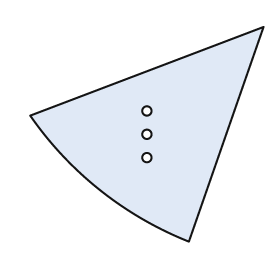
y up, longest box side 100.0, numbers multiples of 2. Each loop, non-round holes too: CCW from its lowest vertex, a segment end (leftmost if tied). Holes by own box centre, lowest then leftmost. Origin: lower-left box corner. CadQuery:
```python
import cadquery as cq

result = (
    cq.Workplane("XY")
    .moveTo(68.0, 0.0)
    .lineTo(100.0, 92.0)
    .lineTo(0.0, 54.0)
    .threePointArc((30.0, 22.0), (68.0, 0.0))
    .close()
    .moveTo(50.0, 36.0)
    .circle(2.0)
    .moveTo(50.0, 46.0)
    .circle(2.0)
    .moveTo(50.0, 56.0)
    .circle(2.0)
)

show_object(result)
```